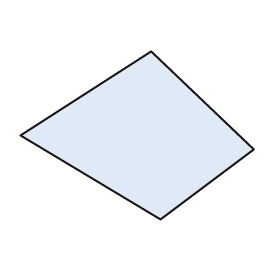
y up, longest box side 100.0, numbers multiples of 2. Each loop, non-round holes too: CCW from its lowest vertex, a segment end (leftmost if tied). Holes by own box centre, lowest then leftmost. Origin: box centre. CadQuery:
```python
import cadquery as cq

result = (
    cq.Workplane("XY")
    .moveTo(10.0, -36.0)
    .lineTo(50.0, -6.0)
    .lineTo(6.0, 36.0)
    .lineTo(-50.0, 0.0)
    .close()
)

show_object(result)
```